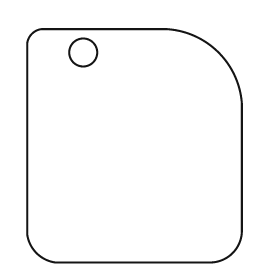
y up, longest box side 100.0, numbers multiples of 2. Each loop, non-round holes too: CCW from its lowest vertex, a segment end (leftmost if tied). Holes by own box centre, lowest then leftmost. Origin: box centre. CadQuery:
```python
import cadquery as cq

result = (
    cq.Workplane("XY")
    .moveTo(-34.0, -50.0)
    .lineTo(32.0, -50.0)
    .threePointArc((42.0, -46.0), (46.0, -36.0))
    .lineTo(46.0, 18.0)
    .threePointArc((36.0, 40.0), (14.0, 50.0))
    .lineTo(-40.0, 50.0)
    .threePointArc((-44.0, 48.0), (-46.0, 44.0))
    .lineTo(-46.0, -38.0)
    .threePointArc((-42.0, -46.0), (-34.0, -50.0))
    .close()
    .moveTo(-22.0, 40.0)
    .circle(6.0)
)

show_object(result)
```